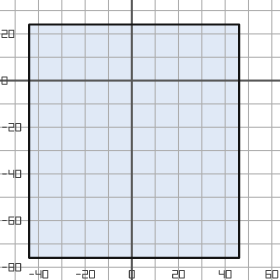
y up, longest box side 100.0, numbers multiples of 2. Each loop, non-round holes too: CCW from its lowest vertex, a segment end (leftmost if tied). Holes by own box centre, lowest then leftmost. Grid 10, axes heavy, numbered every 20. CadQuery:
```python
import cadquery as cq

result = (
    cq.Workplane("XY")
    .moveTo(-44.0, -76.0)
    .lineTo(46.0, -76.0)
    .lineTo(46.0, 24.0)
    .lineTo(-44.0, 24.0)
    .close()
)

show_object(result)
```